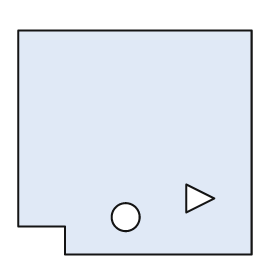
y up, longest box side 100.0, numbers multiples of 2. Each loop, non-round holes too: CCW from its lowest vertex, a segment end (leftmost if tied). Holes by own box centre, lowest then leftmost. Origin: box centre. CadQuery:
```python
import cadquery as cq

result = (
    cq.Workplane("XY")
    .moveTo(-30.0, -48.0)
    .lineTo(50.0, -48.0)
    .lineTo(50.0, 48.0)
    .lineTo(-50.0, 48.0)
    .lineTo(-50.0, -36.0)
    .lineTo(-30.0, -36.0)
    .close()
    .moveTo(-4.0, -32.0)
    .circle(6.0)
    .moveTo(22.0, -30.0)
    .lineTo(34.0, -24.0)
    .lineTo(22.0, -18.0)
    .close()
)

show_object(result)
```